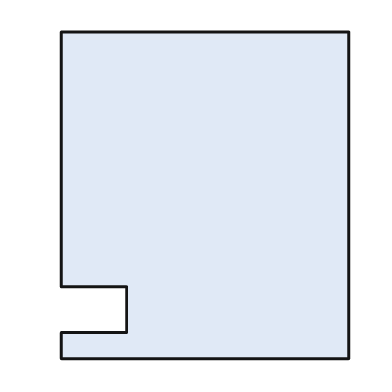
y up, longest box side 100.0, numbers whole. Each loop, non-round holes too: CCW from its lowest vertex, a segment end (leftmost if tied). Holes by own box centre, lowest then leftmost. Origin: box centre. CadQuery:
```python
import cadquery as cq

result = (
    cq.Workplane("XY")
    .moveTo(-44.0, -50.0)
    .lineTo(44.0, -50.0)
    .lineTo(44.0, 50.0)
    .lineTo(-44.0, 50.0)
    .lineTo(-44.0, -28.0)
    .lineTo(-24.0, -28.0)
    .lineTo(-24.0, -42.0)
    .lineTo(-44.0, -42.0)
    .close()
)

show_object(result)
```